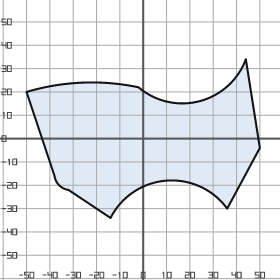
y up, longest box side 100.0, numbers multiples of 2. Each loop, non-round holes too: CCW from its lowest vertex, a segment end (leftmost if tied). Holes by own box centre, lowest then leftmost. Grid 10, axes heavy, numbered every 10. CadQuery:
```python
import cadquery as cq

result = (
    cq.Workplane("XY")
    .moveTo(-14.0, -34.0)
    .threePointArc((10.0, -18.0), (36.0, -30.0))
    .lineTo(50.0, -4.0)
    .lineTo(44.0, 34.0)
    .threePointArc((24.0, 16.0), (-2.0, 22.0))
    .threePointArc((-26.0, 24.0), (-50.0, 20.0))
    .lineTo(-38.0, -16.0)
    .threePointArc((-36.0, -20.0), (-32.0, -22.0))
    .close()
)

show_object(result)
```